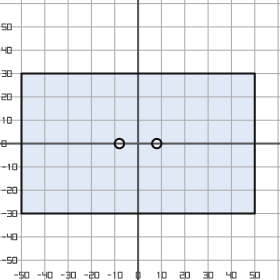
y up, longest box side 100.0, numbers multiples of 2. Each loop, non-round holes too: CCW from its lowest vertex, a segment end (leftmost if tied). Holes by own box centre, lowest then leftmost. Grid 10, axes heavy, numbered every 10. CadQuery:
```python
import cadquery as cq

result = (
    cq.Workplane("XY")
    .moveTo(-50.0, -30.0)
    .lineTo(50.0, -30.0)
    .lineTo(50.0, 30.0)
    .lineTo(-50.0, 30.0)
    .close()
    .moveTo(-8.0, 0.0)
    .circle(2.0)
    .moveTo(8.0, 0.0)
    .circle(2.0)
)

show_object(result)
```